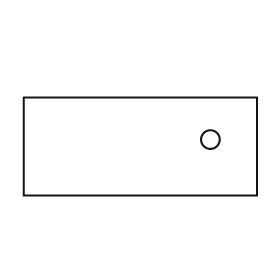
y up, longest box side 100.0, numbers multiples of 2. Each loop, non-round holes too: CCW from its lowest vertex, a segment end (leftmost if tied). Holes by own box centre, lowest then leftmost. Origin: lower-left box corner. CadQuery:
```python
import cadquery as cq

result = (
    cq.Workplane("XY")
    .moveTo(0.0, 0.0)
    .lineTo(100.0, 0.0)
    .lineTo(100.0, 42.0)
    .lineTo(0.0, 42.0)
    .close()
    .moveTo(80.0, 24.0)
    .circle(4.0)
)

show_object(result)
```